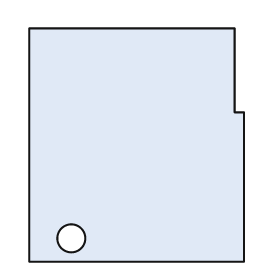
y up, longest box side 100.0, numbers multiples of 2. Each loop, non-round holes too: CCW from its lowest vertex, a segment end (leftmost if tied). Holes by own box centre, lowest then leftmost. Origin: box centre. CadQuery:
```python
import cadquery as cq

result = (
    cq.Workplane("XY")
    .moveTo(-46.0, -50.0)
    .lineTo(46.0, -50.0)
    .lineTo(46.0, 14.0)
    .lineTo(42.0, 14.0)
    .lineTo(42.0, 50.0)
    .lineTo(-46.0, 50.0)
    .close()
    .moveTo(-28.0, -40.0)
    .circle(6.0)
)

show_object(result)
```